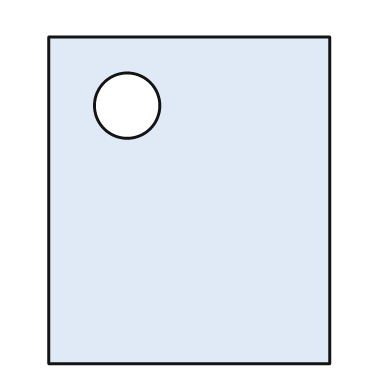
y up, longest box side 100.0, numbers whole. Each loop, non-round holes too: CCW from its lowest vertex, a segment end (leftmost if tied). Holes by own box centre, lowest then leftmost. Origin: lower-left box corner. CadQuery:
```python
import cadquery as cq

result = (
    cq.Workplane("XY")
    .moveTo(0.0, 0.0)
    .lineTo(86.0, 0.0)
    .lineTo(86.0, 100.0)
    .lineTo(0.0, 100.0)
    .close()
    .moveTo(24.0, 79.0)
    .circle(10.0)
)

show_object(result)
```